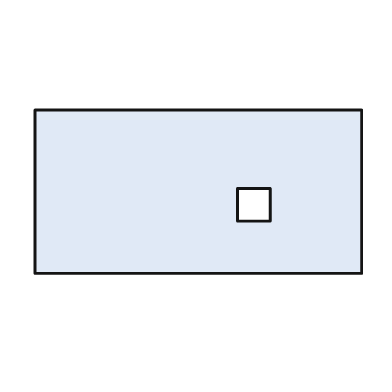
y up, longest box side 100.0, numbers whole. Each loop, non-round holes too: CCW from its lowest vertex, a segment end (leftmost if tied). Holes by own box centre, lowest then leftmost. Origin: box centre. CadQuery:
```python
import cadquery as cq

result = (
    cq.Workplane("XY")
    .moveTo(-50.0, -25.0)
    .lineTo(50.0, -25.0)
    .lineTo(50.0, 25.0)
    .lineTo(-50.0, 25.0)
    .close()
    .moveTo(12.0, -9.0)
    .lineTo(22.0, -9.0)
    .lineTo(22.0, 1.0)
    .lineTo(12.0, 1.0)
    .close()
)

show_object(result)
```